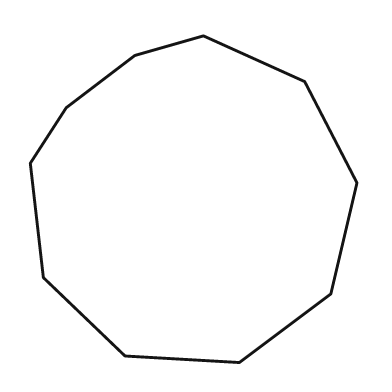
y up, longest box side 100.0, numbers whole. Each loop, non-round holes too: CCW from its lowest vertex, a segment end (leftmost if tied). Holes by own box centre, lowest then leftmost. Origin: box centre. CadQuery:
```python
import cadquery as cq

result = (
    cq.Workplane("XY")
    .moveTo(14.0, -50.0)
    .lineTo(42.0, -29.0)
    .lineTo(50.0, 5.0)
    .lineTo(34.0, 36.0)
    .lineTo(3.0, 50.0)
    .lineTo(-18.0, 44.0)
    .lineTo(-39.0, 28.0)
    .lineTo(-50.0, 11.0)
    .lineTo(-46.0, -24.0)
    .lineTo(-21.0, -48.0)
    .close()
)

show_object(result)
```